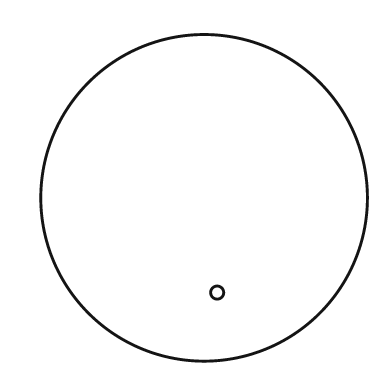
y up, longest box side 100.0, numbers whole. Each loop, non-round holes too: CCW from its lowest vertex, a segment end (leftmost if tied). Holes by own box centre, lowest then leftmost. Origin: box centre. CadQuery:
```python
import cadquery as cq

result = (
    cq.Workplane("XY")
    .moveTo(0.0, 0.0)
    .circle(50.0)
    .moveTo(4.0, -29.0)
    .circle(2.0)
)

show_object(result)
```